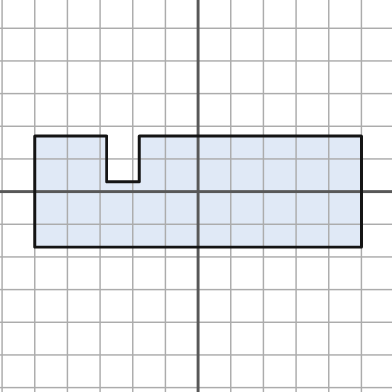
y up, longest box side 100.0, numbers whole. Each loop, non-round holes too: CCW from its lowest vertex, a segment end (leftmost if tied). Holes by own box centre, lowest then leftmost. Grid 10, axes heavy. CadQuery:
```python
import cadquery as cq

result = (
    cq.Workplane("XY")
    .moveTo(-50.0, -17.0)
    .lineTo(50.0, -17.0)
    .lineTo(50.0, 17.0)
    .lineTo(-18.0, 17.0)
    .lineTo(-18.0, 3.0)
    .lineTo(-28.0, 3.0)
    .lineTo(-28.0, 17.0)
    .lineTo(-50.0, 17.0)
    .close()
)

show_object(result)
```